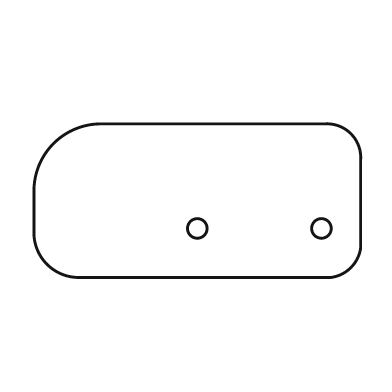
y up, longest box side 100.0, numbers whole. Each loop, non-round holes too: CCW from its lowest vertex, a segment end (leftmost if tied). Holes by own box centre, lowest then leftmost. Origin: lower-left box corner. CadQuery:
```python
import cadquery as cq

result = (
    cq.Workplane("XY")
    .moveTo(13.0, 0.0)
    .lineTo(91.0, 0.0)
    .threePointArc((97.0, 3.0), (100.0, 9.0))
    .lineTo(100.0, 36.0)
    .threePointArc((97.0, 44.0), (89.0, 47.0))
    .lineTo(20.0, 47.0)
    .threePointArc((6.0, 41.0), (0.0, 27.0))
    .lineTo(0.0, 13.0)
    .threePointArc((4.0, 4.0), (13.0, 0.0))
    .close()
    .moveTo(50.0, 15.0)
    .circle(3.0)
    .moveTo(88.0, 15.0)
    .circle(3.0)
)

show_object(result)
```